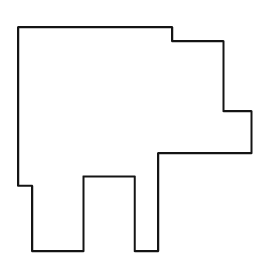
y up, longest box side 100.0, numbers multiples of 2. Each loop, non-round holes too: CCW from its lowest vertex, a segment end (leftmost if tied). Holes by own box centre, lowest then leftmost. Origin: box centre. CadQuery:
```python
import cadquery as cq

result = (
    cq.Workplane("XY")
    .moveTo(-44.0, -48.0)
    .lineTo(-22.0, -48.0)
    .lineTo(-22.0, -16.0)
    .lineTo(0.0, -16.0)
    .lineTo(0.0, -48.0)
    .lineTo(10.0, -48.0)
    .lineTo(10.0, -6.0)
    .lineTo(50.0, -6.0)
    .lineTo(50.0, 12.0)
    .lineTo(38.0, 12.0)
    .lineTo(38.0, 42.0)
    .lineTo(16.0, 42.0)
    .lineTo(16.0, 48.0)
    .lineTo(-50.0, 48.0)
    .lineTo(-50.0, -20.0)
    .lineTo(-44.0, -20.0)
    .close()
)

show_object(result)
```